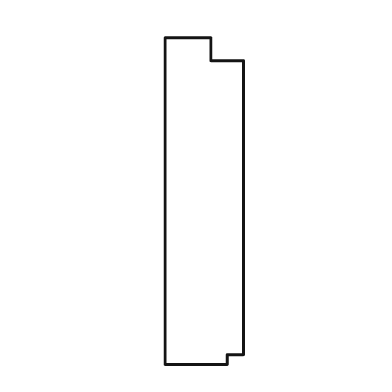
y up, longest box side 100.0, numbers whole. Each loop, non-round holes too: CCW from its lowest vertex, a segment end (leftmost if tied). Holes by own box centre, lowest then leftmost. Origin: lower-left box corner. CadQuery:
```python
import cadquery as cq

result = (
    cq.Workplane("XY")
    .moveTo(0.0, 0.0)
    .lineTo(19.0, 0.0)
    .lineTo(19.0, 3.0)
    .lineTo(24.0, 3.0)
    .lineTo(24.0, 93.0)
    .lineTo(14.0, 93.0)
    .lineTo(14.0, 100.0)
    .lineTo(0.0, 100.0)
    .close()
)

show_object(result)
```